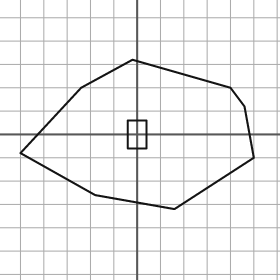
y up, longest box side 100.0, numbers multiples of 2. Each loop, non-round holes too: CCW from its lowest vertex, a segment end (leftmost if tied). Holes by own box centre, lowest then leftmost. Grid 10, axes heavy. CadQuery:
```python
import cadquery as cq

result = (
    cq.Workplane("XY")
    .moveTo(16.0, -32.0)
    .lineTo(50.0, -10.0)
    .lineTo(46.0, 12.0)
    .lineTo(40.0, 20.0)
    .lineTo(-2.0, 32.0)
    .lineTo(-24.0, 20.0)
    .lineTo(-50.0, -8.0)
    .lineTo(-18.0, -26.0)
    .close()
    .moveTo(-4.0, -6.0)
    .lineTo(4.0, -6.0)
    .lineTo(4.0, 6.0)
    .lineTo(-4.0, 6.0)
    .close()
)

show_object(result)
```